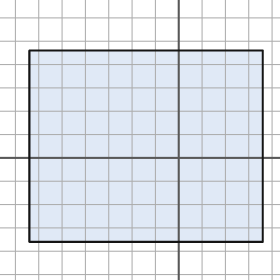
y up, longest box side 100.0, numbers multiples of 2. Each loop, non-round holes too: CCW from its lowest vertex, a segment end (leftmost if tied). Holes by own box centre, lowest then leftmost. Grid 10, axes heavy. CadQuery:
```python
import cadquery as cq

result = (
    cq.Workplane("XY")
    .moveTo(-64.0, -36.0)
    .lineTo(36.0, -36.0)
    .lineTo(36.0, 46.0)
    .lineTo(-64.0, 46.0)
    .close()
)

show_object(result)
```